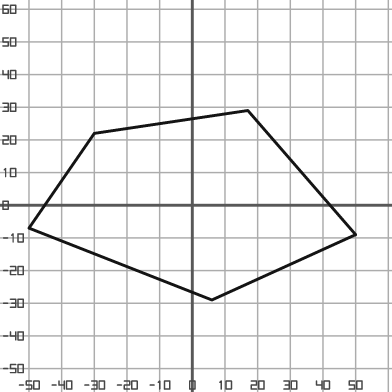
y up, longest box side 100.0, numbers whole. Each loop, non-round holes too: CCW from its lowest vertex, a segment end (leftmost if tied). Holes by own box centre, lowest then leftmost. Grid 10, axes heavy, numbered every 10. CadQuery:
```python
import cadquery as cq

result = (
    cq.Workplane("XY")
    .moveTo(6.0, -29.0)
    .lineTo(50.0, -9.0)
    .lineTo(17.0, 29.0)
    .lineTo(-30.0, 22.0)
    .lineTo(-50.0, -7.0)
    .close()
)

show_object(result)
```